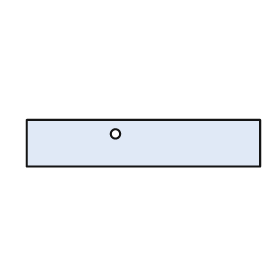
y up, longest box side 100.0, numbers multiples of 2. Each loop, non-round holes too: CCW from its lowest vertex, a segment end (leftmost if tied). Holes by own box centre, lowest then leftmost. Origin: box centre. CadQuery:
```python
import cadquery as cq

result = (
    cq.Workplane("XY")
    .moveTo(-50.0, -10.0)
    .lineTo(50.0, -10.0)
    .lineTo(50.0, 10.0)
    .lineTo(-50.0, 10.0)
    .close()
    .moveTo(-12.0, 4.0)
    .circle(2.0)
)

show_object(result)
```